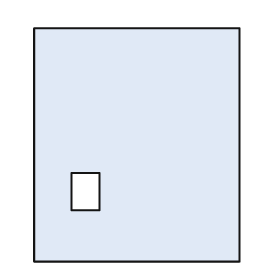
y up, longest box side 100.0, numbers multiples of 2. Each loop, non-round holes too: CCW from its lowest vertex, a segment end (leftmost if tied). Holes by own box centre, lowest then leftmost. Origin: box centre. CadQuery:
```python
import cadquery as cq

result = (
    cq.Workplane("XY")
    .moveTo(-44.0, -50.0)
    .lineTo(44.0, -50.0)
    .lineTo(44.0, 50.0)
    .lineTo(-44.0, 50.0)
    .close()
    .moveTo(-28.0, -28.0)
    .lineTo(-16.0, -28.0)
    .lineTo(-16.0, -12.0)
    .lineTo(-28.0, -12.0)
    .close()
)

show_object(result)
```